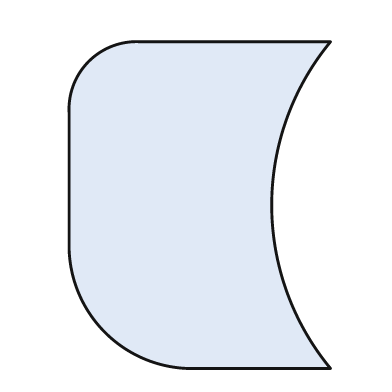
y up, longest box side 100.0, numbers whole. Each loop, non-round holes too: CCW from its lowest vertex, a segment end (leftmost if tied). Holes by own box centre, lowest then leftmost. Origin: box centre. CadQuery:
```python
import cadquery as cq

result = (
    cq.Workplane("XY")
    .moveTo(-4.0, -50.0)
    .lineTo(40.0, -50.0)
    .threePointArc((22.0, 0.0), (40.0, 50.0))
    .lineTo(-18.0, 50.0)
    .threePointArc((-34.0, 44.0), (-40.0, 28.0))
    .lineTo(-40.0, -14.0)
    .threePointArc((-29.0, -39.0), (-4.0, -50.0))
    .close()
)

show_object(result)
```